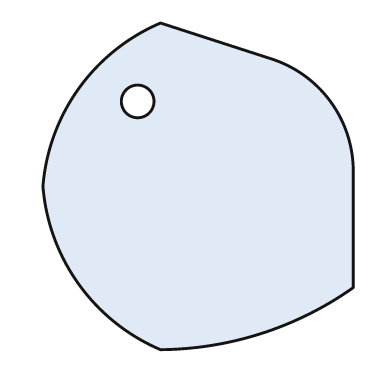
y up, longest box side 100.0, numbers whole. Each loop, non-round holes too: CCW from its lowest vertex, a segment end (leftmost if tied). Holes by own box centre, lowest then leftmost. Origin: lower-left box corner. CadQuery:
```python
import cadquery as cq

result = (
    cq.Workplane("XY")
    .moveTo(36.0, 0.0)
    .threePointArc((67.0, 5.0), (95.0, 19.0))
    .lineTo(95.0, 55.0)
    .threePointArc((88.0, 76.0), (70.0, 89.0))
    .lineTo(36.0, 100.0)
    .threePointArc((11.0, 80.0), (0.0, 50.0))
    .threePointArc((11.0, 20.0), (36.0, 0.0))
    .close()
    .moveTo(29.0, 76.0)
    .circle(5.0)
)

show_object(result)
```